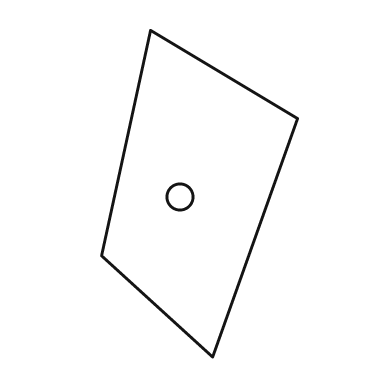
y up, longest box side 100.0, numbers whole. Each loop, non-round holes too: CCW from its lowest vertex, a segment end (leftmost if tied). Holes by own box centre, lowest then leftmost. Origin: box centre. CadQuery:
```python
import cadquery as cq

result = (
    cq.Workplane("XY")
    .moveTo(4.0, -50.0)
    .lineTo(30.0, 23.0)
    .lineTo(-15.0, 50.0)
    .lineTo(-30.0, -19.0)
    .close()
    .moveTo(-6.0, -1.0)
    .circle(4.0)
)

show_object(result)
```